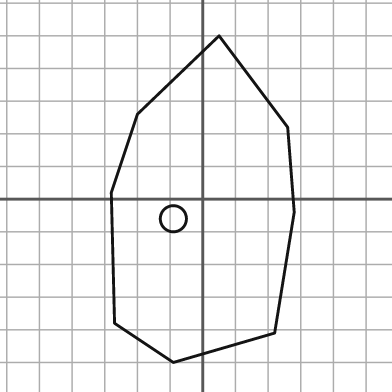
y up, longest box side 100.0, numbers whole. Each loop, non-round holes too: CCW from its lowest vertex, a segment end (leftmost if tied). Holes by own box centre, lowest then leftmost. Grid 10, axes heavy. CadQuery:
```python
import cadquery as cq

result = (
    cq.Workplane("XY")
    .moveTo(-9.0, -50.0)
    .lineTo(22.0, -41.0)
    .lineTo(28.0, -4.0)
    .lineTo(26.0, 22.0)
    .lineTo(5.0, 50.0)
    .lineTo(-20.0, 26.0)
    .lineTo(-28.0, 2.0)
    .lineTo(-27.0, -38.0)
    .close()
    .moveTo(-9.0, -6.0)
    .circle(4.0)
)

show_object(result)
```